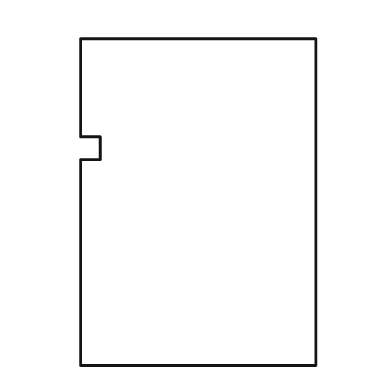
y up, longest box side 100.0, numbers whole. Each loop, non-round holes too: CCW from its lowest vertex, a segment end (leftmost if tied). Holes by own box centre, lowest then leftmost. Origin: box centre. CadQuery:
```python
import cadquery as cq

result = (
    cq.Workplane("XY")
    .moveTo(-36.0, -50.0)
    .lineTo(36.0, -50.0)
    .lineTo(36.0, 50.0)
    .lineTo(-36.0, 50.0)
    .lineTo(-36.0, 20.0)
    .lineTo(-30.0, 20.0)
    .lineTo(-30.0, 13.0)
    .lineTo(-36.0, 13.0)
    .close()
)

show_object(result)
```